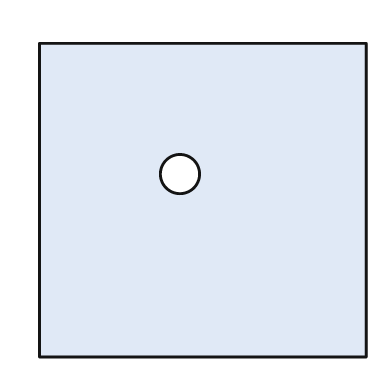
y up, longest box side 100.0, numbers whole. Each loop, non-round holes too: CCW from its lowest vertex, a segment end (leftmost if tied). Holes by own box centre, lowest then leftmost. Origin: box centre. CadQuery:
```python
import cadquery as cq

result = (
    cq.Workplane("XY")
    .moveTo(-50.0, -48.0)
    .lineTo(50.0, -48.0)
    .lineTo(50.0, 48.0)
    .lineTo(-50.0, 48.0)
    .close()
    .moveTo(-7.0, 8.0)
    .circle(6.0)
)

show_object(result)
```